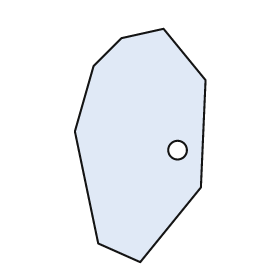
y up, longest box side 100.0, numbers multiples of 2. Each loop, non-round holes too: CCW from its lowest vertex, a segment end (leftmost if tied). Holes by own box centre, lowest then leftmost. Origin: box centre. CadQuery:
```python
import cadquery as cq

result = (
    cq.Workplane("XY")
    .moveTo(0.0, -50.0)
    .lineTo(26.0, -18.0)
    .lineTo(28.0, 28.0)
    .lineTo(10.0, 50.0)
    .lineTo(-8.0, 46.0)
    .lineTo(-20.0, 34.0)
    .lineTo(-28.0, 6.0)
    .lineTo(-18.0, -42.0)
    .close()
    .moveTo(16.0, -2.0)
    .circle(4.0)
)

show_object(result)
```